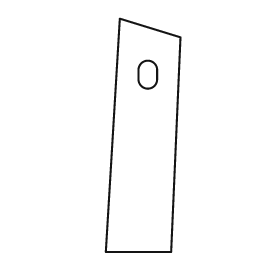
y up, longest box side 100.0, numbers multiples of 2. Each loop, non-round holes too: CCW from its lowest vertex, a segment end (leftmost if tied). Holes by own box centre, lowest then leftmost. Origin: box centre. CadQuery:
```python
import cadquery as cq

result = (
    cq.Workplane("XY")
    .moveTo(-16.0, -50.0)
    .lineTo(12.0, -50.0)
    .lineTo(16.0, 42.0)
    .lineTo(-10.0, 50.0)
    .close()
    .moveTo(-2.0, 24.0)
    .threePointArc((2.0, 20.0), (6.0, 24.0))
    .lineTo(6.0, 28.0)
    .threePointArc((2.0, 32.0), (-2.0, 28.0))
    .close()
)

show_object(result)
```